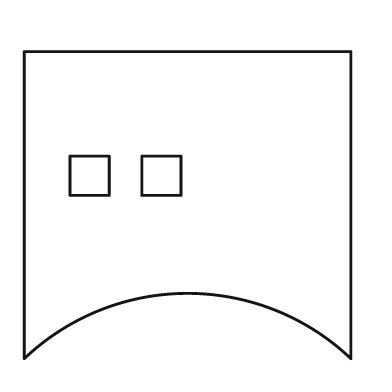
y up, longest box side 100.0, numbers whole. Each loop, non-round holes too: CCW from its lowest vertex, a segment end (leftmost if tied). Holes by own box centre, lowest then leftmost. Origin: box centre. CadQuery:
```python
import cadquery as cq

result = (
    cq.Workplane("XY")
    .moveTo(-50.0, -47.0)
    .threePointArc((0.0, -27.0), (50.0, -47.0))
    .lineTo(50.0, 47.0)
    .lineTo(-50.0, 47.0)
    .close()
    .moveTo(-36.0, 3.0)
    .lineTo(-24.0, 3.0)
    .lineTo(-24.0, 15.0)
    .lineTo(-36.0, 15.0)
    .close()
    .moveTo(-14.0, 3.0)
    .lineTo(-2.0, 3.0)
    .lineTo(-2.0, 15.0)
    .lineTo(-14.0, 15.0)
    .close()
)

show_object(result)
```